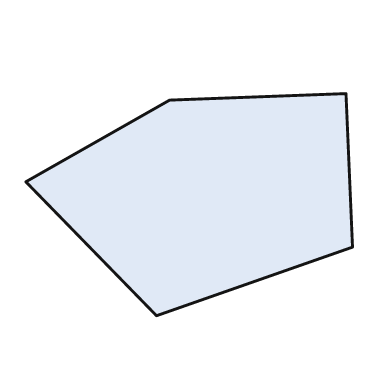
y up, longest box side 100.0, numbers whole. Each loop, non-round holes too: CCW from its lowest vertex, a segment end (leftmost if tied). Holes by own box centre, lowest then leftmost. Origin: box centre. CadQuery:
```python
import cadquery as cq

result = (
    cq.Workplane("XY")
    .moveTo(-10.0, -34.0)
    .lineTo(50.0, -13.0)
    .lineTo(48.0, 34.0)
    .lineTo(-6.0, 32.0)
    .lineTo(-50.0, 7.0)
    .close()
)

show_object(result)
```